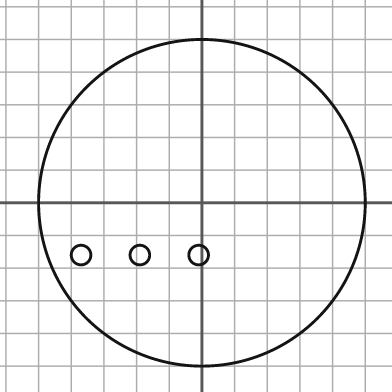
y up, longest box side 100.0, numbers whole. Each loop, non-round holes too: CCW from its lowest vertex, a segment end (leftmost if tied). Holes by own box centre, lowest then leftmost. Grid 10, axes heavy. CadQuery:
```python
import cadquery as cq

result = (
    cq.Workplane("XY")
    .moveTo(0.0, 0.0)
    .circle(50.0)
    .moveTo(-37.0, -16.0)
    .circle(3.0)
    .moveTo(-19.0, -16.0)
    .circle(3.0)
    .moveTo(-1.0, -16.0)
    .circle(3.0)
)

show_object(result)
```